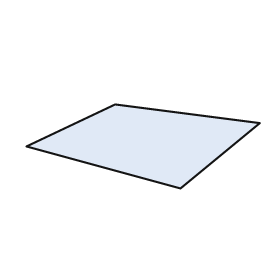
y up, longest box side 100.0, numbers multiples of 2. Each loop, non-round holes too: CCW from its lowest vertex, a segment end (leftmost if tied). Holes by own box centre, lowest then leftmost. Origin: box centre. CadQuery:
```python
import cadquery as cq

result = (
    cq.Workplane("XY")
    .moveTo(16.0, -18.0)
    .lineTo(50.0, 10.0)
    .lineTo(-12.0, 18.0)
    .lineTo(-50.0, 0.0)
    .close()
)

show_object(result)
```